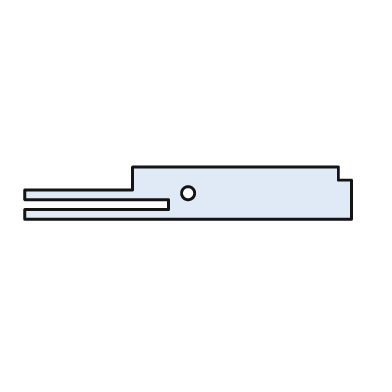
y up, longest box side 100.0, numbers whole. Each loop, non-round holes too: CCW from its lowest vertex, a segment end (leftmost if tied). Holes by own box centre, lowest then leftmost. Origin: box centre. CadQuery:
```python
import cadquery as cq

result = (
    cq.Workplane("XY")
    .moveTo(-50.0, -8.0)
    .lineTo(50.0, -8.0)
    .lineTo(50.0, 4.0)
    .lineTo(46.0, 4.0)
    .lineTo(46.0, 8.0)
    .lineTo(-17.0, 8.0)
    .lineTo(-17.0, 1.0)
    .lineTo(-50.0, 1.0)
    .lineTo(-50.0, -2.0)
    .lineTo(-6.0, -2.0)
    .lineTo(-6.0, -5.0)
    .lineTo(-50.0, -5.0)
    .close()
    .moveTo(0.0, 0.0)
    .circle(2.0)
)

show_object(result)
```